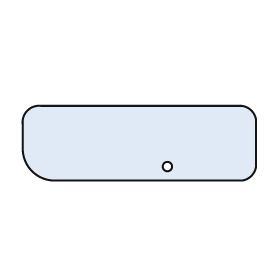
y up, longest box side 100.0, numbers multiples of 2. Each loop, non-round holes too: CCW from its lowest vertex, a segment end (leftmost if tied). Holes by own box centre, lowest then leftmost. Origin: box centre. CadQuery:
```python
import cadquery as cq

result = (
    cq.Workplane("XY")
    .moveTo(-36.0, -16.0)
    .lineTo(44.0, -16.0)
    .threePointArc((48.0, -14.0), (50.0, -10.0))
    .lineTo(50.0, 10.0)
    .threePointArc((48.0, 14.0), (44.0, 16.0))
    .lineTo(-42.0, 16.0)
    .threePointArc((-48.0, 14.0), (-50.0, 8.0))
    .lineTo(-50.0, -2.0)
    .threePointArc((-46.0, -12.0), (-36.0, -16.0))
    .close()
    .moveTo(12.0, -10.0)
    .circle(2.0)
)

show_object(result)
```